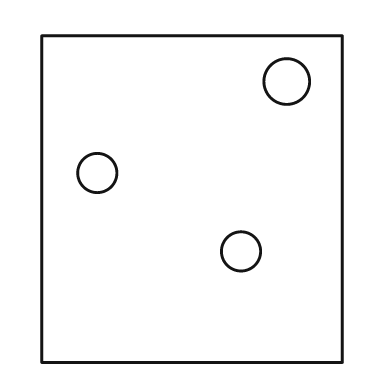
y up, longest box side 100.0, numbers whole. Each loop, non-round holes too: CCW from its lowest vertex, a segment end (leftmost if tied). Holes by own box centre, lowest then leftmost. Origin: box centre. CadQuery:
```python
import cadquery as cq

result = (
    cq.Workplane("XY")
    .moveTo(-46.0, -50.0)
    .lineTo(46.0, -50.0)
    .lineTo(46.0, 50.0)
    .lineTo(-46.0, 50.0)
    .close()
    .moveTo(15.0, -16.0)
    .circle(6.0)
    .moveTo(-29.0, 8.0)
    .circle(6.0)
    .moveTo(29.0, 36.0)
    .circle(7.0)
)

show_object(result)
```